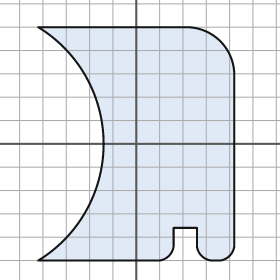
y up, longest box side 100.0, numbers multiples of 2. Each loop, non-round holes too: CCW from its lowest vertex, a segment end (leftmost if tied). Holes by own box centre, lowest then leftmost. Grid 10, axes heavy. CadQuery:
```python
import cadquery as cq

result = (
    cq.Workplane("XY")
    .moveTo(-42.0, -50.0)
    .lineTo(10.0, -50.0)
    .threePointArc((14.0, -48.0), (16.0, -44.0))
    .lineTo(16.0, -36.0)
    .lineTo(26.0, -36.0)
    .lineTo(26.0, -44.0)
    .threePointArc((28.0, -48.0), (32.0, -50.0))
    .lineTo(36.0, -50.0)
    .threePointArc((40.0, -48.0), (42.0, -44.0))
    .lineTo(42.0, 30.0)
    .threePointArc((36.0, 44.0), (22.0, 50.0))
    .lineTo(-42.0, 50.0)
    .threePointArc((-14.0, 0.0), (-42.0, -50.0))
    .close()
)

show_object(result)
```